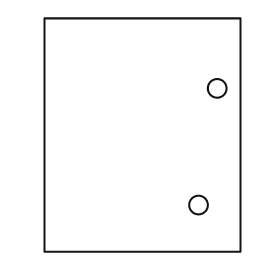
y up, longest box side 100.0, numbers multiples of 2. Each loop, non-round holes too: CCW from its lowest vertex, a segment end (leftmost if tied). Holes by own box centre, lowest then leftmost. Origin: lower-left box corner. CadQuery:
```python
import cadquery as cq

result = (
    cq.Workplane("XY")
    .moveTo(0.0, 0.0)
    .lineTo(84.0, 0.0)
    .lineTo(84.0, 100.0)
    .lineTo(0.0, 100.0)
    .close()
    .moveTo(66.0, 20.0)
    .circle(4.0)
    .moveTo(74.0, 70.0)
    .circle(4.0)
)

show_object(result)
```